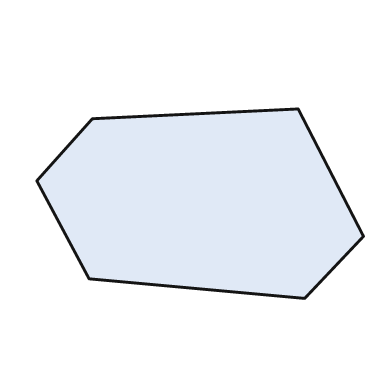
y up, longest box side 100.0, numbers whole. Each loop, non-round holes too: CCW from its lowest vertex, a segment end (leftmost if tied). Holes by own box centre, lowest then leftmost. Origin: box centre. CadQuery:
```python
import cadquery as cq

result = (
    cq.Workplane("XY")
    .moveTo(32.0, -29.0)
    .lineTo(50.0, -10.0)
    .lineTo(30.0, 29.0)
    .lineTo(-33.0, 26.0)
    .lineTo(-50.0, 7.0)
    .lineTo(-34.0, -23.0)
    .close()
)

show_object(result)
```